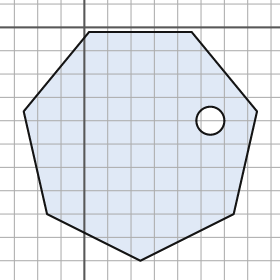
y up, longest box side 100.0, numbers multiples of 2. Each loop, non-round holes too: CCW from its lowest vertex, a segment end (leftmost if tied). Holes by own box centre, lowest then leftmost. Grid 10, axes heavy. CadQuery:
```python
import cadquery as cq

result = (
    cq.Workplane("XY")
    .moveTo(24.0, -100.0)
    .lineTo(64.0, -80.0)
    .lineTo(74.0, -36.0)
    .lineTo(46.0, -2.0)
    .lineTo(2.0, -2.0)
    .lineTo(-26.0, -36.0)
    .lineTo(-16.0, -80.0)
    .close()
    .moveTo(54.0, -40.0)
    .circle(6.0)
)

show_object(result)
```